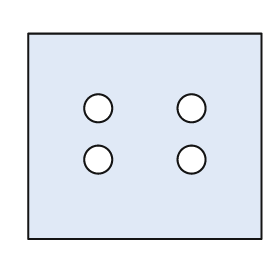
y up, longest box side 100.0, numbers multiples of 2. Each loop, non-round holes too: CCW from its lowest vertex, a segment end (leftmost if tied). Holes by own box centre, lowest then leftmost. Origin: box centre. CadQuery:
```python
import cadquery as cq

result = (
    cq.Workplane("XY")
    .moveTo(-50.0, -44.0)
    .lineTo(50.0, -44.0)
    .lineTo(50.0, 44.0)
    .lineTo(-50.0, 44.0)
    .close()
    .moveTo(-20.0, -10.0)
    .circle(6.0)
    .moveTo(20.0, -10.0)
    .circle(6.0)
    .moveTo(-20.0, 12.0)
    .circle(6.0)
    .moveTo(20.0, 12.0)
    .circle(6.0)
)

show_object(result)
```